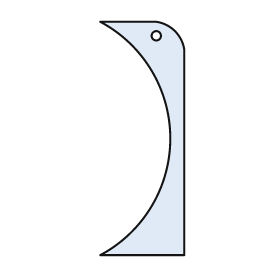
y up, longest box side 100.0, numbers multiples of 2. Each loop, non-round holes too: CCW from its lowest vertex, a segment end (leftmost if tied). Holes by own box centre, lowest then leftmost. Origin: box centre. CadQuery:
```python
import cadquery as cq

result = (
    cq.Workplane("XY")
    .moveTo(-18.0, -50.0)
    .lineTo(18.0, -50.0)
    .lineTo(18.0, 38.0)
    .threePointArc((14.0, 46.0), (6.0, 50.0))
    .lineTo(-18.0, 50.0)
    .threePointArc((12.0, 0.0), (-18.0, -50.0))
    .close()
    .moveTo(6.0, 44.0)
    .circle(2.0)
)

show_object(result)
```